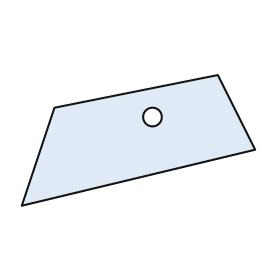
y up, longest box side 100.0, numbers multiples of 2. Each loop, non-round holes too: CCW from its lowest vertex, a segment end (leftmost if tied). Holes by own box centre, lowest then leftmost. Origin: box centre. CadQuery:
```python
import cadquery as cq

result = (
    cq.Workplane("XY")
    .moveTo(-50.0, -28.0)
    .lineTo(50.0, -4.0)
    .lineTo(34.0, 28.0)
    .lineTo(-36.0, 14.0)
    .close()
    .moveTo(6.0, 10.0)
    .circle(4.0)
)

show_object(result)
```